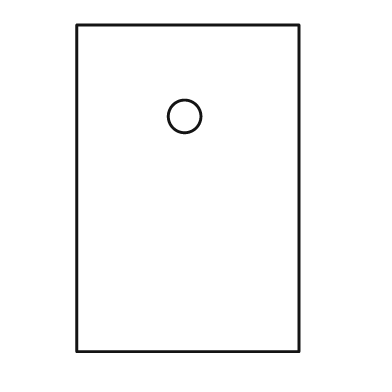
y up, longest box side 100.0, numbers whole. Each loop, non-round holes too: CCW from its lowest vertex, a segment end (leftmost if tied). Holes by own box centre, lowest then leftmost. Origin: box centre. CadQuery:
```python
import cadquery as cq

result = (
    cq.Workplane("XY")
    .moveTo(-34.0, -50.0)
    .lineTo(34.0, -50.0)
    .lineTo(34.0, 50.0)
    .lineTo(-34.0, 50.0)
    .close()
    .moveTo(-1.0, 22.0)
    .circle(5.0)
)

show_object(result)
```